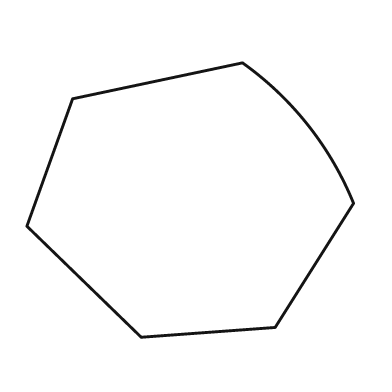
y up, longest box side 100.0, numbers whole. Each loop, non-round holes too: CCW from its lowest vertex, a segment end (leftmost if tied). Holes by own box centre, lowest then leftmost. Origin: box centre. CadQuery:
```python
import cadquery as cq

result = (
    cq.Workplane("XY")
    .moveTo(-15.0, -42.0)
    .lineTo(26.0, -39.0)
    .lineTo(50.0, -1.0)
    .threePointArc((36.0, 23.0), (16.0, 42.0))
    .lineTo(-36.0, 31.0)
    .lineTo(-50.0, -8.0)
    .close()
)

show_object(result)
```